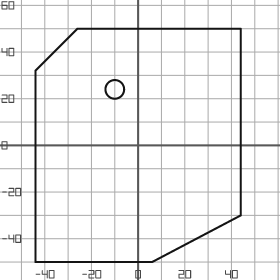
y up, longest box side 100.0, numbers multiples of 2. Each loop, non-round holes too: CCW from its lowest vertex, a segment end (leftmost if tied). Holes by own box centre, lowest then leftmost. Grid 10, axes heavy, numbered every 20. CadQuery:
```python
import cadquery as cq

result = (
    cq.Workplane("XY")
    .moveTo(-44.0, -50.0)
    .lineTo(6.0, -50.0)
    .lineTo(44.0, -30.0)
    .lineTo(44.0, 50.0)
    .lineTo(-26.0, 50.0)
    .lineTo(-44.0, 32.0)
    .close()
    .moveTo(-10.0, 24.0)
    .circle(4.0)
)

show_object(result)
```